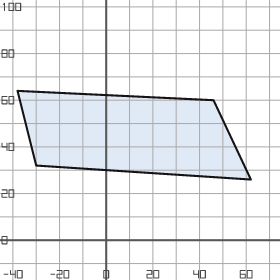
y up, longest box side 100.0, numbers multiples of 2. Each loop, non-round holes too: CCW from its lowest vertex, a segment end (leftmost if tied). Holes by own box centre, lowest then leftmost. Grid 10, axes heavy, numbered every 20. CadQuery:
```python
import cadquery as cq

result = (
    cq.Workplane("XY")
    .moveTo(62.0, 26.0)
    .lineTo(46.0, 60.0)
    .lineTo(-38.0, 64.0)
    .lineTo(-30.0, 32.0)
    .close()
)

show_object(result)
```